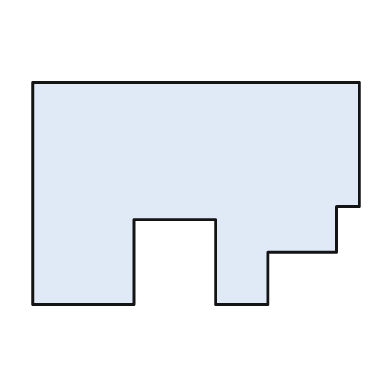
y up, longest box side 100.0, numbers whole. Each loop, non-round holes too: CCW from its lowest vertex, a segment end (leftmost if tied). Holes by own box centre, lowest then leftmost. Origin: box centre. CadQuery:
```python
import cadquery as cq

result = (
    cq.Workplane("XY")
    .moveTo(-50.0, -34.0)
    .lineTo(-19.0, -34.0)
    .lineTo(-19.0, -8.0)
    .lineTo(6.0, -8.0)
    .lineTo(6.0, -34.0)
    .lineTo(22.0, -34.0)
    .lineTo(22.0, -18.0)
    .lineTo(43.0, -18.0)
    .lineTo(43.0, -4.0)
    .lineTo(50.0, -4.0)
    .lineTo(50.0, 34.0)
    .lineTo(-50.0, 34.0)
    .close()
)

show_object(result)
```